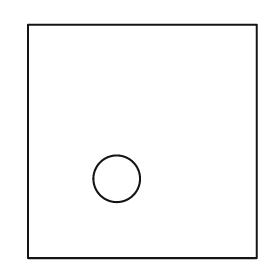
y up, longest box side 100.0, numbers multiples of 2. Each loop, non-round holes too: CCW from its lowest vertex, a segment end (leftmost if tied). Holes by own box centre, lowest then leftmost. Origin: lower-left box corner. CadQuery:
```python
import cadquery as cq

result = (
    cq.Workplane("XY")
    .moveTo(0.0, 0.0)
    .lineTo(98.0, 0.0)
    .lineTo(98.0, 100.0)
    .lineTo(0.0, 100.0)
    .close()
    .moveTo(38.0, 34.0)
    .circle(10.0)
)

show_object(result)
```